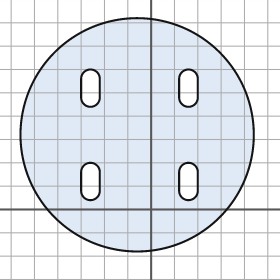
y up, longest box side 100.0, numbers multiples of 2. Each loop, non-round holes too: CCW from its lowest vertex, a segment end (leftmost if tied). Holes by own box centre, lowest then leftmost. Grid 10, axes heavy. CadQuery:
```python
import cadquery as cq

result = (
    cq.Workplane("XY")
    .moveTo(-6.0, 32.0)
    .circle(50.0)
    .moveTo(-30.0, 8.0)
    .threePointArc((-26.0, 4.0), (-22.0, 8.0))
    .lineTo(-22.0, 16.0)
    .threePointArc((-26.0, 20.0), (-30.0, 16.0))
    .close()
    .moveTo(12.0, 8.0)
    .threePointArc((16.0, 4.0), (20.0, 8.0))
    .lineTo(20.0, 16.0)
    .threePointArc((16.0, 20.0), (12.0, 16.0))
    .close()
    .moveTo(-30.0, 48.0)
    .threePointArc((-26.0, 44.0), (-22.0, 48.0))
    .lineTo(-22.0, 56.0)
    .threePointArc((-26.0, 60.0), (-30.0, 56.0))
    .close()
    .moveTo(12.0, 48.0)
    .threePointArc((16.0, 44.0), (20.0, 48.0))
    .lineTo(20.0, 56.0)
    .threePointArc((16.0, 60.0), (12.0, 56.0))
    .close()
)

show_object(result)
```